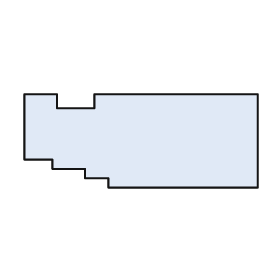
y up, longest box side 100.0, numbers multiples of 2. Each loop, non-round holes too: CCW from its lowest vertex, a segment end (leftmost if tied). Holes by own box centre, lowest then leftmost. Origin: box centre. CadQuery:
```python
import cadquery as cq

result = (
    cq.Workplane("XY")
    .moveTo(-14.0, -20.0)
    .lineTo(50.0, -20.0)
    .lineTo(50.0, 20.0)
    .lineTo(-20.0, 20.0)
    .lineTo(-20.0, 14.0)
    .lineTo(-36.0, 14.0)
    .lineTo(-36.0, 20.0)
    .lineTo(-50.0, 20.0)
    .lineTo(-50.0, -8.0)
    .lineTo(-38.0, -8.0)
    .lineTo(-38.0, -12.0)
    .lineTo(-24.0, -12.0)
    .lineTo(-24.0, -16.0)
    .lineTo(-14.0, -16.0)
    .close()
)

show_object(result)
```